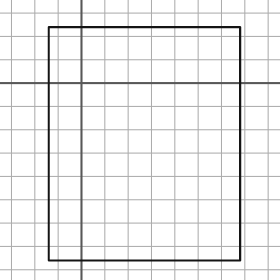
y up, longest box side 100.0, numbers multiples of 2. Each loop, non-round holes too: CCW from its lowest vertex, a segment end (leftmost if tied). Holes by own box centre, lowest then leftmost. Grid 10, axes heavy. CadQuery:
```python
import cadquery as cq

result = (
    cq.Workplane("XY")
    .moveTo(-14.0, -76.0)
    .lineTo(68.0, -76.0)
    .lineTo(68.0, 24.0)
    .lineTo(-14.0, 24.0)
    .close()
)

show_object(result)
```